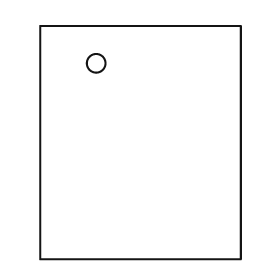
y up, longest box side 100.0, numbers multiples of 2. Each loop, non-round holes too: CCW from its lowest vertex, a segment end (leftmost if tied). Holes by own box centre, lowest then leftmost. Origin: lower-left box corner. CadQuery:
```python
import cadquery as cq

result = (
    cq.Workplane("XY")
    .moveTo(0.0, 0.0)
    .lineTo(86.0, 0.0)
    .lineTo(86.0, 100.0)
    .lineTo(0.0, 100.0)
    .close()
    .moveTo(24.0, 84.0)
    .circle(4.0)
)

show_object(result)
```